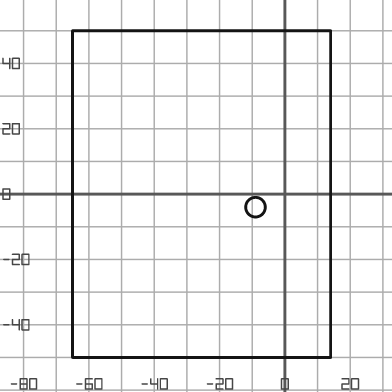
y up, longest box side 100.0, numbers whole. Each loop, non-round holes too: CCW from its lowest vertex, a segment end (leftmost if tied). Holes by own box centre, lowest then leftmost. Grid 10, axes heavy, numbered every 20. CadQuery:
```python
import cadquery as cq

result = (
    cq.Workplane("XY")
    .moveTo(-65.0, -50.0)
    .lineTo(14.0, -50.0)
    .lineTo(14.0, 50.0)
    .lineTo(-65.0, 50.0)
    .close()
    .moveTo(-9.0, -4.0)
    .circle(3.0)
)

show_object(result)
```